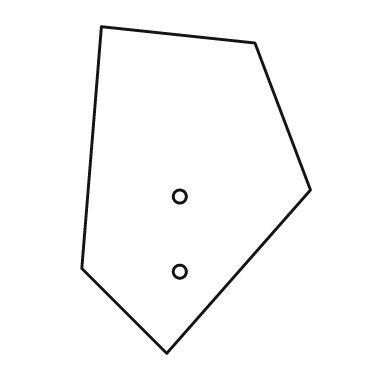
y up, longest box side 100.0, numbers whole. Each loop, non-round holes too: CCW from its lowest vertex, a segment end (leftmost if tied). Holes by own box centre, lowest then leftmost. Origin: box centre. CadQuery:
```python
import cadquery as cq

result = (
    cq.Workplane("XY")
    .moveTo(-9.0, -50.0)
    .lineTo(35.0, 0.0)
    .lineTo(18.0, 45.0)
    .lineTo(-29.0, 50.0)
    .lineTo(-35.0, -24.0)
    .close()
    .moveTo(-5.0, -25.0)
    .circle(2.0)
    .moveTo(-5.0, -2.0)
    .circle(2.0)
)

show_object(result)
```